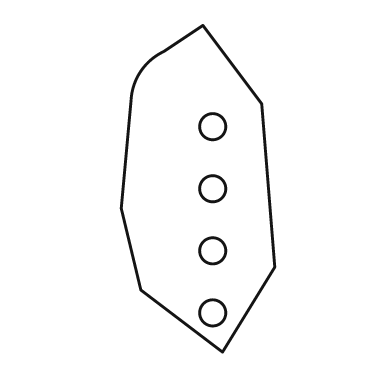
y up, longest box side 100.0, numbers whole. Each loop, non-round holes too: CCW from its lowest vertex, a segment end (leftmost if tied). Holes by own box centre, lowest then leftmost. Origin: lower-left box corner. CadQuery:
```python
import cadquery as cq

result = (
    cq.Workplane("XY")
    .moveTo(31.0, 0.0)
    .lineTo(47.0, 26.0)
    .lineTo(43.0, 76.0)
    .lineTo(25.0, 100.0)
    .lineTo(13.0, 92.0)
    .threePointArc((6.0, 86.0), (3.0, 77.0))
    .lineTo(0.0, 44.0)
    .lineTo(6.0, 19.0)
    .close()
    .moveTo(28.0, 12.0)
    .circle(4.0)
    .moveTo(28.0, 31.0)
    .circle(4.0)
    .moveTo(28.0, 50.0)
    .circle(4.0)
    .moveTo(28.0, 69.0)
    .circle(4.0)
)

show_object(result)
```